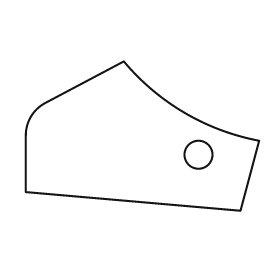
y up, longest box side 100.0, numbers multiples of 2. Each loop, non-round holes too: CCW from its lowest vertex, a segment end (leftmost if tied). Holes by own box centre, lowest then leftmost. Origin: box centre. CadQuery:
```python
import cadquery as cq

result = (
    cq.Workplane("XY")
    .moveTo(42.0, -32.0)
    .lineTo(50.0, -2.0)
    .threePointArc((18.0, 10.0), (-8.0, 32.0))
    .lineTo(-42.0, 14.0)
    .threePointArc((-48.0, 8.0), (-50.0, 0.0))
    .lineTo(-50.0, -24.0)
    .close()
    .moveTo(24.0, -8.0)
    .circle(6.0)
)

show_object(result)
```